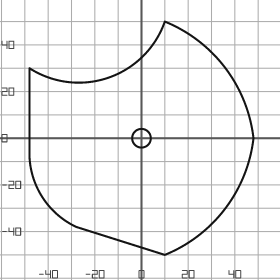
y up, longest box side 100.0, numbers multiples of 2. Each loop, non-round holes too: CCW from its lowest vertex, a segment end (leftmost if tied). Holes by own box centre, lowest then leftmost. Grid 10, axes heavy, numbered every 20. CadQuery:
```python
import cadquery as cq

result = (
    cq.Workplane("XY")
    .moveTo(10.0, -50.0)
    .threePointArc((36.0, -30.0), (48.0, 0.0))
    .threePointArc((36.0, 30.0), (10.0, 50.0))
    .threePointArc((-14.0, 26.0), (-48.0, 30.0))
    .lineTo(-48.0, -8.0)
    .threePointArc((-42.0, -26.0), (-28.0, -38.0))
    .close()
    .moveTo(0.0, 0.0)
    .circle(4.0)
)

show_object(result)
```